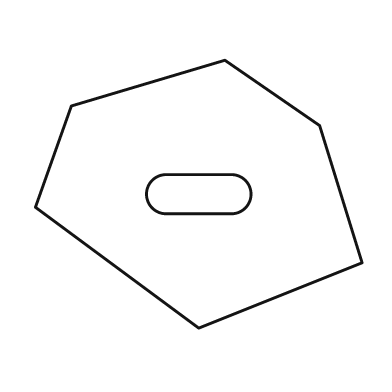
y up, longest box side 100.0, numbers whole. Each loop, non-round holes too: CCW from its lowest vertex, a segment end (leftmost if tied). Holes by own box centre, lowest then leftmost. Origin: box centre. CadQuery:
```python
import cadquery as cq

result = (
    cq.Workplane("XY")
    .moveTo(0.0, -41.0)
    .lineTo(50.0, -21.0)
    .lineTo(37.0, 21.0)
    .lineTo(8.0, 41.0)
    .lineTo(-39.0, 27.0)
    .lineTo(-50.0, -4.0)
    .close()
    .moveTo(-10.0, -6.0)
    .lineTo(10.0, -6.0)
    .threePointArc((16.0, 0.0), (10.0, 6.0))
    .lineTo(-10.0, 6.0)
    .threePointArc((-16.0, 0.0), (-10.0, -6.0))
    .close()
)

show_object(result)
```